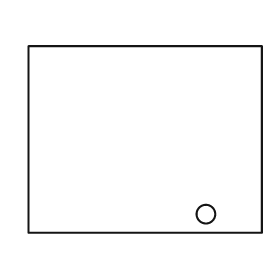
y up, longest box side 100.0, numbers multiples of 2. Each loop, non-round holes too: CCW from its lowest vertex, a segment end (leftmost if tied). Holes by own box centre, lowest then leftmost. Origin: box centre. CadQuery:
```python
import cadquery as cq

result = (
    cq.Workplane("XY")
    .moveTo(-50.0, -40.0)
    .lineTo(50.0, -40.0)
    .lineTo(50.0, 40.0)
    .lineTo(-50.0, 40.0)
    .close()
    .moveTo(26.0, -32.0)
    .circle(4.0)
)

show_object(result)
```